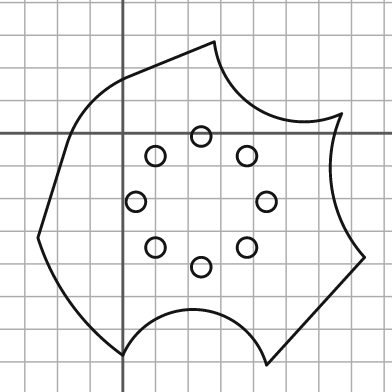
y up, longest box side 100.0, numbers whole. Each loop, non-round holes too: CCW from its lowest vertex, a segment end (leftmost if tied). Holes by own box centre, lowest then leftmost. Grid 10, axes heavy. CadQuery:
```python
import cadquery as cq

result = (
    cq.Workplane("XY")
    .moveTo(44.0, -71.0)
    .lineTo(74.0, -38.0)
    .threePointArc((64.0, -17.0), (67.0, 6.0))
    .threePointArc((42.0, 7.0), (28.0, 28.0))
    .lineTo(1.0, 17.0)
    .threePointArc((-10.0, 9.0), (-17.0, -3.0))
    .lineTo(-26.0, -32.0)
    .threePointArc((-16.0, -52.0), (0.0, -68.0))
    .threePointArc((23.0, -54.0), (44.0, -71.0))
    .close()
    .moveTo(24.0, -41.0)
    .circle(3.0)
    .moveTo(10.0, -35.0)
    .circle(3.0)
    .moveTo(38.0, -35.0)
    .circle(3.0)
    .moveTo(4.0, -21.0)
    .circle(3.0)
    .moveTo(44.0, -21.0)
    .circle(3.0)
    .moveTo(10.0, -7.0)
    .circle(3.0)
    .moveTo(38.0, -7.0)
    .circle(3.0)
    .moveTo(24.0, -1.0)
    .circle(3.0)
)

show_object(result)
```